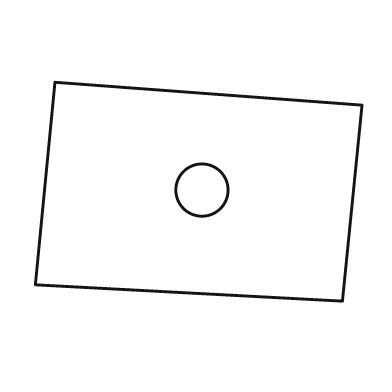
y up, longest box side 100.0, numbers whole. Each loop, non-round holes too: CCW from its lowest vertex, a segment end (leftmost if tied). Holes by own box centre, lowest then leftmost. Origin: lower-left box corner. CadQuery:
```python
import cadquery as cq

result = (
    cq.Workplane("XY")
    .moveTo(94.0, 0.0)
    .lineTo(100.0, 60.0)
    .lineTo(6.0, 67.0)
    .lineTo(0.0, 5.0)
    .close()
    .moveTo(51.0, 34.0)
    .circle(8.0)
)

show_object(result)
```